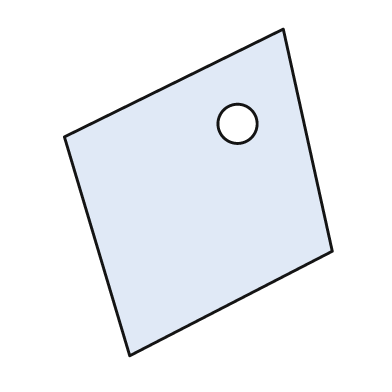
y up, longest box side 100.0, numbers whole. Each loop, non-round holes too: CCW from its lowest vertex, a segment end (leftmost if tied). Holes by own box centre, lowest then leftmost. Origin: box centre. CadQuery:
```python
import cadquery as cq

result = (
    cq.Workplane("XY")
    .moveTo(-21.0, -50.0)
    .lineTo(41.0, -18.0)
    .lineTo(26.0, 50.0)
    .lineTo(-41.0, 17.0)
    .close()
    .moveTo(12.0, 21.0)
    .circle(6.0)
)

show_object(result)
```